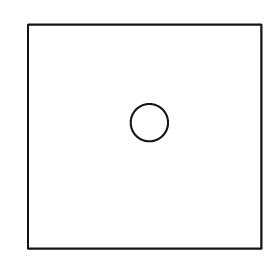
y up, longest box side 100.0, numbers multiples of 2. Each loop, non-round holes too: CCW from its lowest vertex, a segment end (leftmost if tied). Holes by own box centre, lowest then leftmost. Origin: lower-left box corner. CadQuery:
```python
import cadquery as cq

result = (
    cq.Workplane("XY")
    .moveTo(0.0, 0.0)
    .lineTo(100.0, 0.0)
    .lineTo(100.0, 96.0)
    .lineTo(0.0, 96.0)
    .close()
    .moveTo(52.0, 54.0)
    .circle(8.0)
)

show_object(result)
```